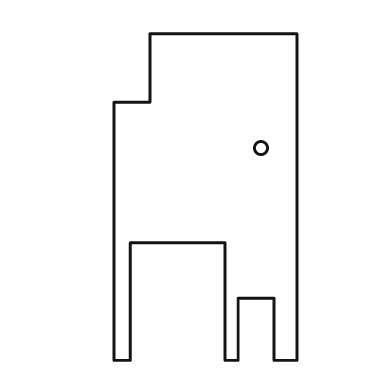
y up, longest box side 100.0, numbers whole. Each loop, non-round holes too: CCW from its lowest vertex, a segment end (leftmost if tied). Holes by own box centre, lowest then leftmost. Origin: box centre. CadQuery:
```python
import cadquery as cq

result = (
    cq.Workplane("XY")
    .moveTo(-28.0, -50.0)
    .lineTo(-23.0, -50.0)
    .lineTo(-23.0, -14.0)
    .lineTo(6.0, -14.0)
    .lineTo(6.0, -50.0)
    .lineTo(10.0, -50.0)
    .lineTo(10.0, -31.0)
    .lineTo(21.0, -31.0)
    .lineTo(21.0, -50.0)
    .lineTo(28.0, -50.0)
    .lineTo(28.0, 50.0)
    .lineTo(-17.0, 50.0)
    .lineTo(-17.0, 29.0)
    .lineTo(-28.0, 29.0)
    .close()
    .moveTo(17.0, 15.0)
    .circle(2.0)
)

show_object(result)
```